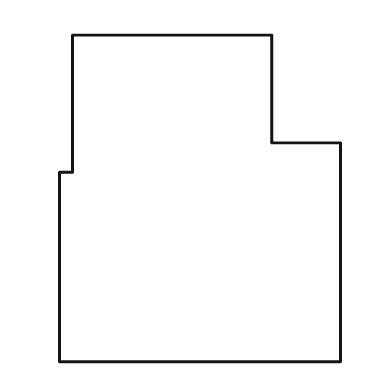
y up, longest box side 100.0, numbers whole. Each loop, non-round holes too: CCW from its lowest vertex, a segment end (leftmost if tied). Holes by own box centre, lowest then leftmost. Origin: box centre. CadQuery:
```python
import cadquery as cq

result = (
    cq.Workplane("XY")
    .moveTo(-43.0, -50.0)
    .lineTo(43.0, -50.0)
    .lineTo(43.0, 17.0)
    .lineTo(22.0, 17.0)
    .lineTo(22.0, 50.0)
    .lineTo(-39.0, 50.0)
    .lineTo(-39.0, 8.0)
    .lineTo(-43.0, 8.0)
    .close()
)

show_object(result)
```